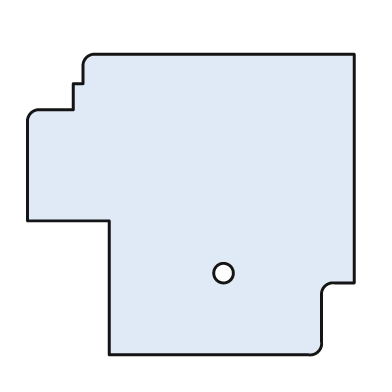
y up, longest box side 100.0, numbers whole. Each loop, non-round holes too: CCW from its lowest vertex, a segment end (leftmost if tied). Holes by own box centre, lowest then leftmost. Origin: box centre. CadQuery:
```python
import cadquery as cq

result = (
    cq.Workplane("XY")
    .moveTo(-25.0, -46.0)
    .lineTo(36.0, -46.0)
    .threePointArc((39.0, -45.0), (40.0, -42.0))
    .lineTo(40.0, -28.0)
    .threePointArc((41.0, -25.0), (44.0, -24.0))
    .lineTo(50.0, -24.0)
    .lineTo(50.0, 46.0)
    .lineTo(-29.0, 46.0)
    .threePointArc((-32.0, 45.0), (-33.0, 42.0))
    .lineTo(-33.0, 37.0)
    .lineTo(-36.0, 37.0)
    .lineTo(-36.0, 29.0)
    .lineTo(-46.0, 29.0)
    .threePointArc((-49.0, 28.0), (-50.0, 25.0))
    .lineTo(-50.0, -5.0)
    .lineTo(-25.0, -5.0)
    .close()
    .moveTo(10.0, -21.0)
    .circle(3.0)
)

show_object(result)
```